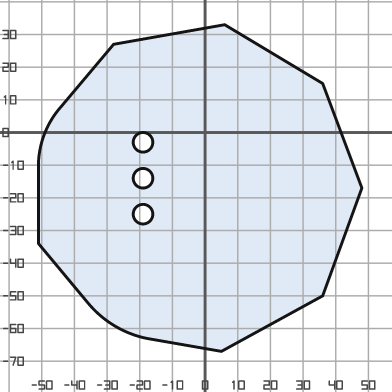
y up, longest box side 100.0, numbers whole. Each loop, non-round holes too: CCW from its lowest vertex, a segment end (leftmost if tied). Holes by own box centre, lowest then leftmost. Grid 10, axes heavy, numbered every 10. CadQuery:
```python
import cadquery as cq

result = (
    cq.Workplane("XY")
    .moveTo(5.0, -67.0)
    .lineTo(36.0, -50.0)
    .lineTo(48.0, -17.0)
    .lineTo(36.0, 15.0)
    .lineTo(6.0, 33.0)
    .lineTo(-28.0, 27.0)
    .lineTo(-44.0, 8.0)
    .threePointArc((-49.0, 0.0), (-51.0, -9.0))
    .lineTo(-51.0, -34.0)
    .lineTo(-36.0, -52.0)
    .threePointArc((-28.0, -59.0), (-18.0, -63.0))
    .close()
    .moveTo(-19.0, -25.0)
    .circle(3.0)
    .moveTo(-19.0, -14.0)
    .circle(3.0)
    .moveTo(-19.0, -3.0)
    .circle(3.0)
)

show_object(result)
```